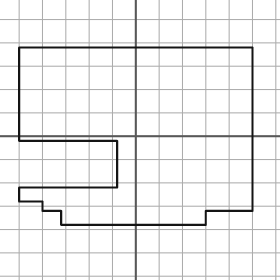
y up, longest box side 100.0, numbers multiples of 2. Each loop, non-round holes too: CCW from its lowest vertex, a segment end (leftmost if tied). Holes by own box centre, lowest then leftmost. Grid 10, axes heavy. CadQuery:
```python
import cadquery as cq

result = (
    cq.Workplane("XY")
    .moveTo(-32.0, -38.0)
    .lineTo(30.0, -38.0)
    .lineTo(30.0, -32.0)
    .lineTo(50.0, -32.0)
    .lineTo(50.0, 38.0)
    .lineTo(-50.0, 38.0)
    .lineTo(-50.0, -2.0)
    .lineTo(-8.0, -2.0)
    .lineTo(-8.0, -22.0)
    .lineTo(-50.0, -22.0)
    .lineTo(-50.0, -28.0)
    .lineTo(-40.0, -28.0)
    .lineTo(-40.0, -32.0)
    .lineTo(-32.0, -32.0)
    .close()
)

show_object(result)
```